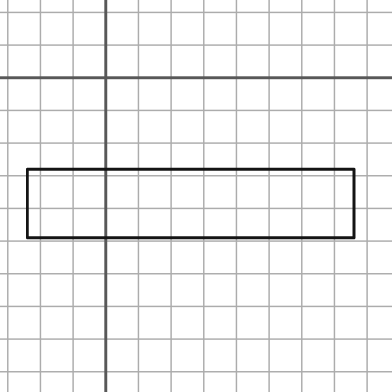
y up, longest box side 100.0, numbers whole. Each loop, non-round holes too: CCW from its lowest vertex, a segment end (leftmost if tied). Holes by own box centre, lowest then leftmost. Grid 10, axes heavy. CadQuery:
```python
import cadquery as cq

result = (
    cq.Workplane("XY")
    .moveTo(-24.0, -49.0)
    .lineTo(76.0, -49.0)
    .lineTo(76.0, -28.0)
    .lineTo(-24.0, -28.0)
    .close()
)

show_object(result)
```